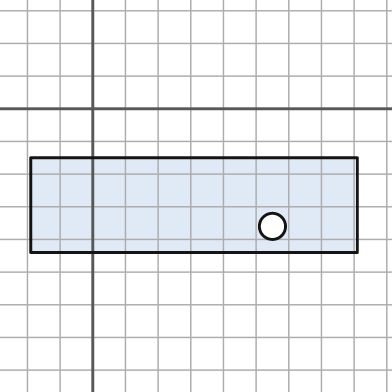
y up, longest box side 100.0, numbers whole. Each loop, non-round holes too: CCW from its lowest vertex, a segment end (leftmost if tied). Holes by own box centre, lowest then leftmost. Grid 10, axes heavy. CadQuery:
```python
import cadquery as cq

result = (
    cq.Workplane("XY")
    .moveTo(-19.0, -44.0)
    .lineTo(81.0, -44.0)
    .lineTo(81.0, -15.0)
    .lineTo(-19.0, -15.0)
    .close()
    .moveTo(55.0, -36.0)
    .circle(4.0)
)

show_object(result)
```